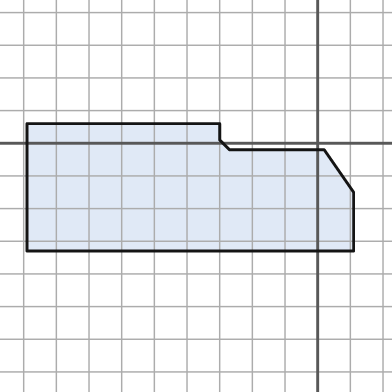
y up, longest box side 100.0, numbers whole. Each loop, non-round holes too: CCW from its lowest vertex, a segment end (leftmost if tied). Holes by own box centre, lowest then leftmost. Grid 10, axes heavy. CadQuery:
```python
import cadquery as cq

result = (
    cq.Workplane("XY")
    .moveTo(-89.0, -33.0)
    .lineTo(11.0, -33.0)
    .lineTo(11.0, -15.0)
    .lineTo(2.0, -2.0)
    .lineTo(-27.0, -2.0)
    .lineTo(-30.0, 1.0)
    .lineTo(-30.0, 6.0)
    .lineTo(-89.0, 6.0)
    .close()
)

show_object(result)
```